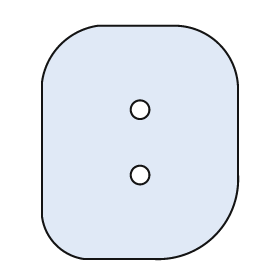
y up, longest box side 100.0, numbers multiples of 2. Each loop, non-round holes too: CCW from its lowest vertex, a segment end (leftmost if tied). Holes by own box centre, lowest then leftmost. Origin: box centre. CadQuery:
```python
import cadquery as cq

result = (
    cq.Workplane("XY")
    .moveTo(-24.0, -50.0)
    .lineTo(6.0, -50.0)
    .threePointArc((32.0, -40.0), (42.0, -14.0))
    .lineTo(42.0, 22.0)
    .threePointArc((34.0, 42.0), (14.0, 50.0))
    .lineTo(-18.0, 50.0)
    .threePointArc((-34.0, 42.0), (-42.0, 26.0))
    .lineTo(-42.0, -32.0)
    .threePointArc((-36.0, -44.0), (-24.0, -50.0))
    .close()
    .moveTo(0.0, -14.0)
    .circle(4.0)
    .moveTo(0.0, 14.0)
    .circle(4.0)
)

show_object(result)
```